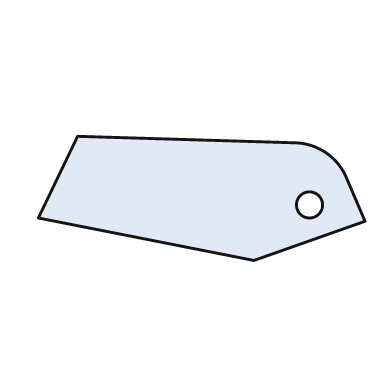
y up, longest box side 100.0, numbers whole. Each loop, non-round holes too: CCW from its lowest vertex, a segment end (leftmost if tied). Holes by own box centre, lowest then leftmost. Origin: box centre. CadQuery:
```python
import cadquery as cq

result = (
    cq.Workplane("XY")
    .moveTo(16.0, -19.0)
    .lineTo(50.0, -7.0)
    .lineTo(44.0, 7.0)
    .threePointArc((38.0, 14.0), (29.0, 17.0))
    .lineTo(-38.0, 19.0)
    .lineTo(-50.0, -6.0)
    .close()
    .moveTo(33.0, -2.0)
    .circle(4.0)
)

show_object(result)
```